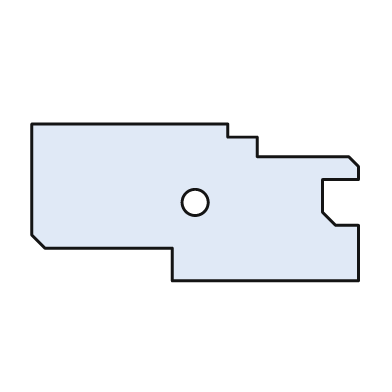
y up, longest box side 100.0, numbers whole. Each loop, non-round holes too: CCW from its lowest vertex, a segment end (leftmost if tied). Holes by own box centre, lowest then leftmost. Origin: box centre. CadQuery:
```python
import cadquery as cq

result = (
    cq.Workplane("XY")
    .moveTo(-7.0, -24.0)
    .lineTo(50.0, -24.0)
    .lineTo(50.0, -7.0)
    .lineTo(43.0, -7.0)
    .lineTo(39.0, -3.0)
    .lineTo(39.0, 7.0)
    .lineTo(50.0, 7.0)
    .lineTo(50.0, 11.0)
    .lineTo(47.0, 14.0)
    .lineTo(19.0, 14.0)
    .lineTo(19.0, 20.0)
    .lineTo(10.0, 20.0)
    .lineTo(10.0, 24.0)
    .lineTo(-50.0, 24.0)
    .lineTo(-50.0, -10.0)
    .lineTo(-46.0, -14.0)
    .lineTo(-7.0, -14.0)
    .close()
    .moveTo(0.0, 0.0)
    .circle(4.0)
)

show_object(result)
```